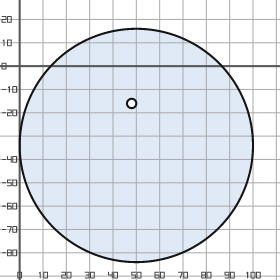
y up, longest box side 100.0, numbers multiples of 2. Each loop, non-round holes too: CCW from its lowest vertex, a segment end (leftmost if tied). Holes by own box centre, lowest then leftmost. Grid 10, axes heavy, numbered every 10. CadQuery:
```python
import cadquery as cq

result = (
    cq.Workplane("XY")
    .moveTo(50.0, -34.0)
    .circle(50.0)
    .moveTo(48.0, -16.0)
    .circle(2.0)
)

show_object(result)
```